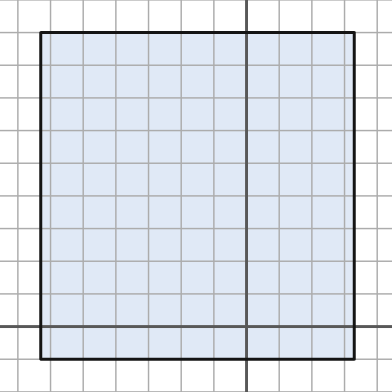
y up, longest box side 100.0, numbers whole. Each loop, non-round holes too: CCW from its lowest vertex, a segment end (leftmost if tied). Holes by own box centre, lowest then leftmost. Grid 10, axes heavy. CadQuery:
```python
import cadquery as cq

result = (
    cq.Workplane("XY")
    .moveTo(-63.0, -10.0)
    .lineTo(33.0, -10.0)
    .lineTo(33.0, 90.0)
    .lineTo(-63.0, 90.0)
    .close()
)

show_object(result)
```